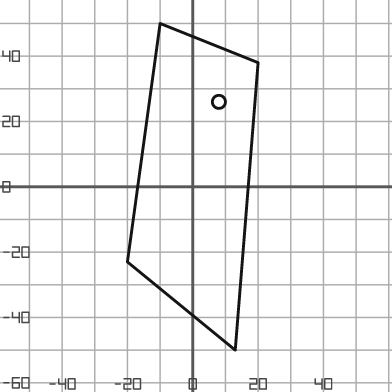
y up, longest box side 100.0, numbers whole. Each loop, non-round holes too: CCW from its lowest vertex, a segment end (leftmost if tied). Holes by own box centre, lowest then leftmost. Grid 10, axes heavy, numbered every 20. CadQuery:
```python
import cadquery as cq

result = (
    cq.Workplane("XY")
    .moveTo(13.0, -50.0)
    .lineTo(20.0, 38.0)
    .lineTo(-10.0, 50.0)
    .lineTo(-20.0, -23.0)
    .close()
    .moveTo(8.0, 26.0)
    .circle(2.0)
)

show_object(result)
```